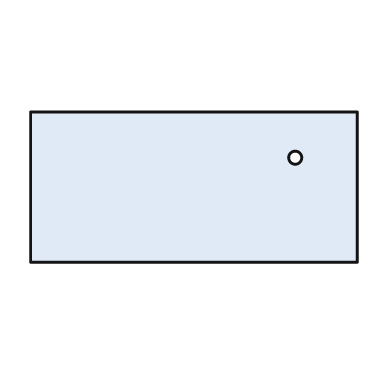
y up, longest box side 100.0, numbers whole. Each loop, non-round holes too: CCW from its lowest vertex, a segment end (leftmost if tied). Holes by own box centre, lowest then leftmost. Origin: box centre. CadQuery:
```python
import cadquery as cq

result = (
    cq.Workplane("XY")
    .moveTo(-50.0, -23.0)
    .lineTo(50.0, -23.0)
    .lineTo(50.0, 23.0)
    .lineTo(-50.0, 23.0)
    .close()
    .moveTo(31.0, 9.0)
    .circle(2.0)
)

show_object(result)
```